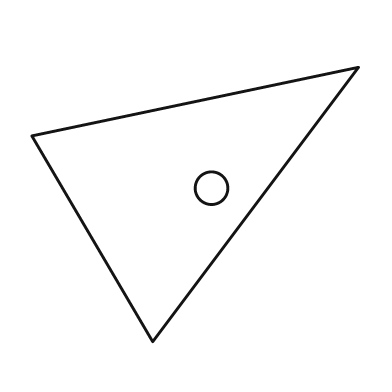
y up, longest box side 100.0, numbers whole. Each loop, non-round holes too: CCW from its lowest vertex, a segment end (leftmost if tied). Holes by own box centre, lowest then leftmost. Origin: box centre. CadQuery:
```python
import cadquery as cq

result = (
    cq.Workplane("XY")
    .moveTo(-13.0, -42.0)
    .lineTo(50.0, 42.0)
    .lineTo(-50.0, 21.0)
    .close()
    .moveTo(5.0, 5.0)
    .circle(5.0)
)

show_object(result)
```